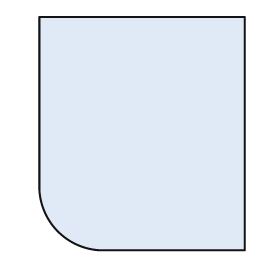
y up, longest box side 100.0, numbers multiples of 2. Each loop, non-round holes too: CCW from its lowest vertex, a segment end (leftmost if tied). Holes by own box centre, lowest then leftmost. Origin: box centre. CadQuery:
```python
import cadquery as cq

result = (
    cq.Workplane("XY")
    .moveTo(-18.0, -50.0)
    .lineTo(44.0, -50.0)
    .lineTo(44.0, 50.0)
    .lineTo(-44.0, 50.0)
    .lineTo(-44.0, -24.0)
    .threePointArc((-36.0, -42.0), (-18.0, -50.0))
    .close()
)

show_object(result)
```